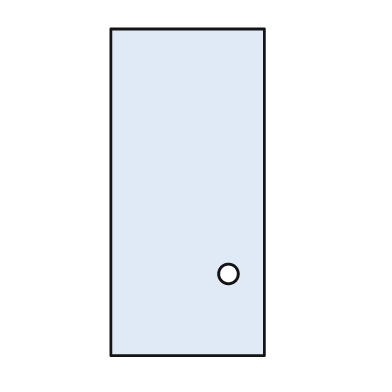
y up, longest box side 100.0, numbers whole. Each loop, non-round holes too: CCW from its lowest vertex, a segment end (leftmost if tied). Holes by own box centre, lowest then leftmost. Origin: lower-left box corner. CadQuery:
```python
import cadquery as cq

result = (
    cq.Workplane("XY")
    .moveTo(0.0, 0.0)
    .lineTo(47.0, 0.0)
    .lineTo(47.0, 100.0)
    .lineTo(0.0, 100.0)
    .close()
    .moveTo(36.0, 25.0)
    .circle(3.0)
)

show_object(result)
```